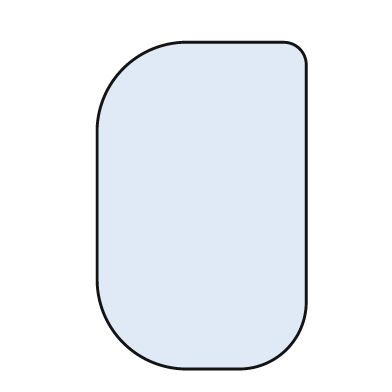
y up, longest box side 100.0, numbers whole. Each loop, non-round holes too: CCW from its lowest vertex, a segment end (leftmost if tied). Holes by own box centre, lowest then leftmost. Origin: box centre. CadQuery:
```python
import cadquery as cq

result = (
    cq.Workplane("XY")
    .moveTo(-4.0, -50.0)
    .lineTo(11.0, -50.0)
    .threePointArc((26.0, -44.0), (32.0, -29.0))
    .lineTo(32.0, 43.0)
    .threePointArc((30.0, 48.0), (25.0, 50.0))
    .lineTo(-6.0, 50.0)
    .threePointArc((-24.0, 42.0), (-32.0, 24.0))
    .lineTo(-32.0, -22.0)
    .threePointArc((-24.0, -42.0), (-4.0, -50.0))
    .close()
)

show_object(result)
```